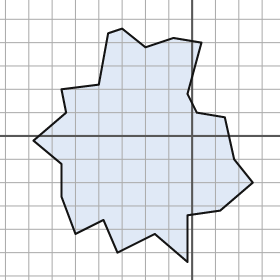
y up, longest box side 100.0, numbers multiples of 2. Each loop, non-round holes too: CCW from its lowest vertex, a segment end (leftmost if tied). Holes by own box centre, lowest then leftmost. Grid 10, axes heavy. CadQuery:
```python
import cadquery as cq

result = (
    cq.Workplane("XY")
    .moveTo(-2.0, -54.0)
    .lineTo(-2.0, -34.0)
    .lineTo(12.0, -32.0)
    .lineTo(26.0, -20.0)
    .lineTo(18.0, -10.0)
    .lineTo(14.0, 8.0)
    .lineTo(2.0, 10.0)
    .lineTo(-2.0, 18.0)
    .lineTo(4.0, 40.0)
    .lineTo(-8.0, 42.0)
    .lineTo(-20.0, 38.0)
    .lineTo(-30.0, 46.0)
    .lineTo(-36.0, 44.0)
    .lineTo(-40.0, 22.0)
    .lineTo(-56.0, 20.0)
    .lineTo(-54.0, 10.0)
    .lineTo(-68.0, -2.0)
    .lineTo(-56.0, -12.0)
    .lineTo(-56.0, -26.0)
    .lineTo(-50.0, -42.0)
    .lineTo(-38.0, -36.0)
    .lineTo(-32.0, -50.0)
    .lineTo(-16.0, -42.0)
    .close()
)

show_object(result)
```